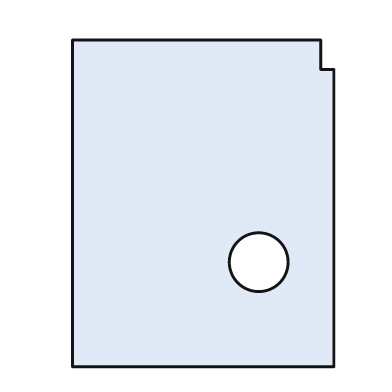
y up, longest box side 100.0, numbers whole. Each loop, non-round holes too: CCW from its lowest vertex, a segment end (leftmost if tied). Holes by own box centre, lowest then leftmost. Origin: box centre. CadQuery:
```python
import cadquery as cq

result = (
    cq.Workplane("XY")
    .moveTo(-40.0, -50.0)
    .lineTo(40.0, -50.0)
    .lineTo(40.0, 41.0)
    .lineTo(36.0, 41.0)
    .lineTo(36.0, 50.0)
    .lineTo(-40.0, 50.0)
    .close()
    .moveTo(17.0, -18.0)
    .circle(9.0)
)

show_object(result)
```